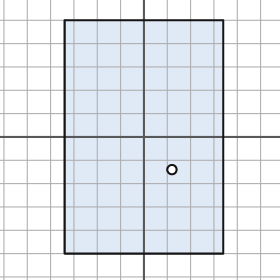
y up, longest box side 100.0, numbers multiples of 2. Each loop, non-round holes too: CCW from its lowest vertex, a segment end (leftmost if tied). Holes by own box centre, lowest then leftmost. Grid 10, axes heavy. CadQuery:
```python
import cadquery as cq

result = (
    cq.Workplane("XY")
    .moveTo(-34.0, -50.0)
    .lineTo(34.0, -50.0)
    .lineTo(34.0, 50.0)
    .lineTo(-34.0, 50.0)
    .close()
    .moveTo(12.0, -14.0)
    .circle(2.0)
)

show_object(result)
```